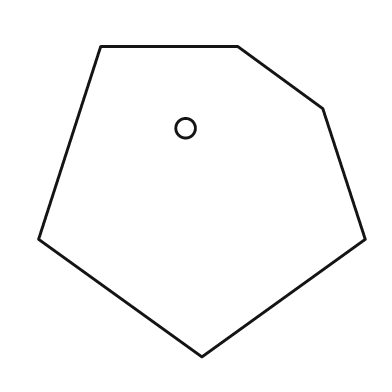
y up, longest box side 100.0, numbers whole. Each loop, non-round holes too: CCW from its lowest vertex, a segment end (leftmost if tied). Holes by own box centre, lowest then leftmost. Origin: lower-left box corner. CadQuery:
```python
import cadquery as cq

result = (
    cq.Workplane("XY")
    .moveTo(50.0, 0.0)
    .lineTo(100.0, 36.0)
    .lineTo(87.0, 76.0)
    .lineTo(61.0, 95.0)
    .lineTo(19.0, 95.0)
    .lineTo(0.0, 36.0)
    .close()
    .moveTo(45.0, 70.0)
    .circle(3.0)
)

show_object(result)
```